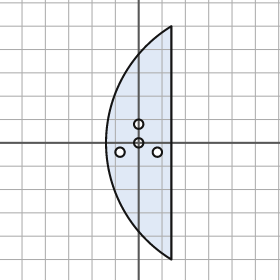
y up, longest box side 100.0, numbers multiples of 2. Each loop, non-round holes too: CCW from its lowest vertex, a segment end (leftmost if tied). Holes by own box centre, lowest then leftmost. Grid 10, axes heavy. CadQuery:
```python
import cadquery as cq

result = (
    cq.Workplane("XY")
    .moveTo(14.0, -50.0)
    .lineTo(14.0, 50.0)
    .threePointArc((-14.0, 0.0), (14.0, -50.0))
    .close()
    .moveTo(-8.0, -4.0)
    .circle(2.0)
    .moveTo(8.0, -4.0)
    .circle(2.0)
    .moveTo(0.0, 0.0)
    .circle(2.0)
    .moveTo(0.0, 8.0)
    .circle(2.0)
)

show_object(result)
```